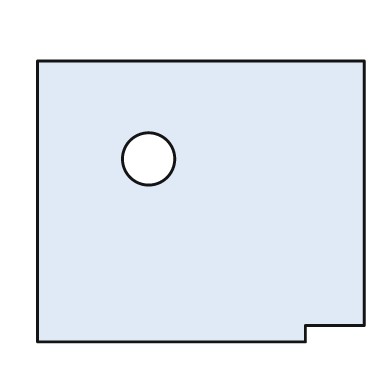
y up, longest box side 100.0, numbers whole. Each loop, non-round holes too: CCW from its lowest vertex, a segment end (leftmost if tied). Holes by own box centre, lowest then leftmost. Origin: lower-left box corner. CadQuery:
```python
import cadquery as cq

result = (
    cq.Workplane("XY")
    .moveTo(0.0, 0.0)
    .lineTo(82.0, 0.0)
    .lineTo(82.0, 5.0)
    .lineTo(100.0, 5.0)
    .lineTo(100.0, 86.0)
    .lineTo(0.0, 86.0)
    .close()
    .moveTo(34.0, 56.0)
    .circle(8.0)
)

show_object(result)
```